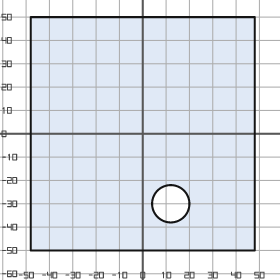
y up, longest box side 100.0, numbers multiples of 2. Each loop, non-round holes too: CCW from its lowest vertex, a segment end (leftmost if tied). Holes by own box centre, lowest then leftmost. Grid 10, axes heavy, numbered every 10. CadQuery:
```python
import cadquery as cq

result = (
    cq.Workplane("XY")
    .moveTo(-48.0, -50.0)
    .lineTo(48.0, -50.0)
    .lineTo(48.0, 50.0)
    .lineTo(-48.0, 50.0)
    .close()
    .moveTo(12.0, -30.0)
    .circle(8.0)
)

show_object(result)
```